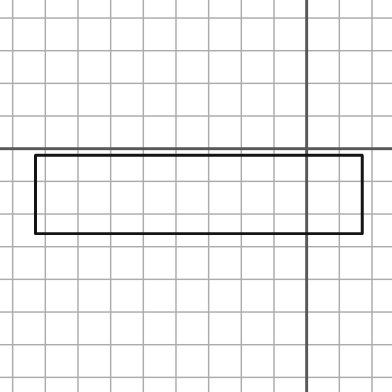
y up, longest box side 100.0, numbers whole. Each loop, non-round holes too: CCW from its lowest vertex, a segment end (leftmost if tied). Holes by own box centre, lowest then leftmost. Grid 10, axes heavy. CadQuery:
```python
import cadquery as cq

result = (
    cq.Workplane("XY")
    .moveTo(-83.0, -26.0)
    .lineTo(17.0, -26.0)
    .lineTo(17.0, -2.0)
    .lineTo(-83.0, -2.0)
    .close()
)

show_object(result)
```